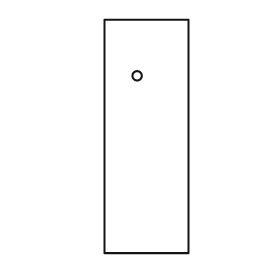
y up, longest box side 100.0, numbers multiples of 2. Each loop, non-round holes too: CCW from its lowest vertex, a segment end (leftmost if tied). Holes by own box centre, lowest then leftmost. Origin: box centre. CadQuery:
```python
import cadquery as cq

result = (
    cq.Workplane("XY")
    .moveTo(-18.0, -50.0)
    .lineTo(18.0, -50.0)
    .lineTo(18.0, 50.0)
    .lineTo(-18.0, 50.0)
    .close()
    .moveTo(-4.0, 26.0)
    .circle(2.0)
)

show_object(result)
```